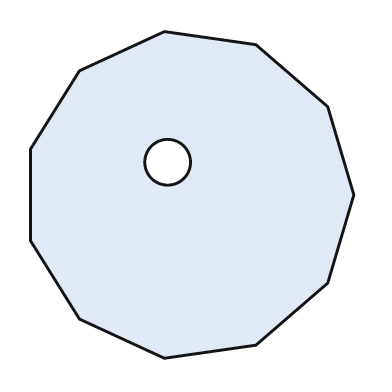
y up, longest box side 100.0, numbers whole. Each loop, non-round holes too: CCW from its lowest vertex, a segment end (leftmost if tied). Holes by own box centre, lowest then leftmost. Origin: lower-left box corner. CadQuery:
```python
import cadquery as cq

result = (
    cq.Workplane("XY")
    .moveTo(41.0, 0.0)
    .lineTo(69.0, 4.0)
    .lineTo(91.0, 23.0)
    .lineTo(99.0, 50.0)
    .lineTo(91.0, 77.0)
    .lineTo(69.0, 96.0)
    .lineTo(41.0, 100.0)
    .lineTo(15.0, 88.0)
    .lineTo(0.0, 64.0)
    .lineTo(0.0, 36.0)
    .lineTo(15.0, 12.0)
    .close()
    .moveTo(42.0, 60.0)
    .circle(7.0)
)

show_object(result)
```